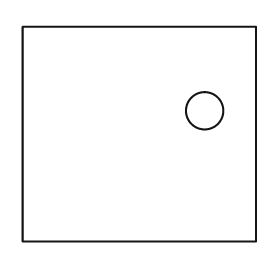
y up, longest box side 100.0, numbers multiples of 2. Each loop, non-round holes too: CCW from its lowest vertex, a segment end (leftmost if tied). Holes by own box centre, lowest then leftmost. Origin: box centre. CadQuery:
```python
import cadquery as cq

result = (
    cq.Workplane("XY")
    .moveTo(-50.0, -46.0)
    .lineTo(50.0, -46.0)
    .lineTo(50.0, 46.0)
    .lineTo(-50.0, 46.0)
    .close()
    .moveTo(28.0, 10.0)
    .circle(8.0)
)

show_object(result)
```